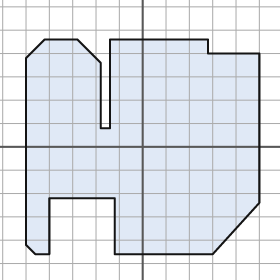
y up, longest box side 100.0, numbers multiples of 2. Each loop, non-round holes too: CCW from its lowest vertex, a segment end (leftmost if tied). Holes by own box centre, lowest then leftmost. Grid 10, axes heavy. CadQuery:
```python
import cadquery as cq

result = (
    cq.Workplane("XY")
    .moveTo(-46.0, -46.0)
    .lineTo(-40.0, -46.0)
    .lineTo(-40.0, -22.0)
    .lineTo(-12.0, -22.0)
    .lineTo(-12.0, -46.0)
    .lineTo(30.0, -46.0)
    .lineTo(50.0, -24.0)
    .lineTo(50.0, 40.0)
    .lineTo(28.0, 40.0)
    .lineTo(28.0, 46.0)
    .lineTo(-14.0, 46.0)
    .lineTo(-14.0, 8.0)
    .lineTo(-18.0, 8.0)
    .lineTo(-18.0, 36.0)
    .lineTo(-28.0, 46.0)
    .lineTo(-42.0, 46.0)
    .lineTo(-50.0, 38.0)
    .lineTo(-50.0, -42.0)
    .close()
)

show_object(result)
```